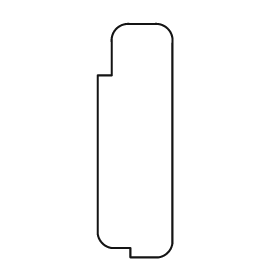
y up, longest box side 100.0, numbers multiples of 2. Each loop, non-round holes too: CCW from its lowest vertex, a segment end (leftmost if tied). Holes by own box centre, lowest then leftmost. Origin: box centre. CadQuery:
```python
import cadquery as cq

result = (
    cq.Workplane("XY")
    .moveTo(-2.0, -50.0)
    .lineTo(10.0, -50.0)
    .threePointArc((14.0, -48.0), (16.0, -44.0))
    .lineTo(16.0, 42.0)
    .threePointArc((14.0, 48.0), (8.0, 50.0))
    .lineTo(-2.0, 50.0)
    .threePointArc((-8.0, 48.0), (-10.0, 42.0))
    .lineTo(-10.0, 28.0)
    .lineTo(-16.0, 28.0)
    .lineTo(-16.0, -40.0)
    .threePointArc((-14.0, -44.0), (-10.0, -46.0))
    .lineTo(-2.0, -46.0)
    .close()
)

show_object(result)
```